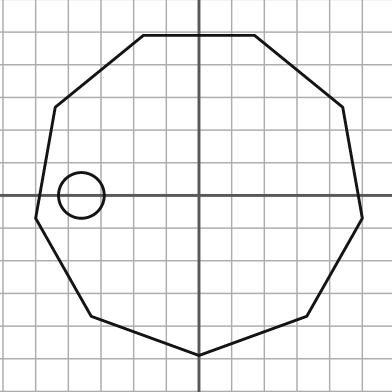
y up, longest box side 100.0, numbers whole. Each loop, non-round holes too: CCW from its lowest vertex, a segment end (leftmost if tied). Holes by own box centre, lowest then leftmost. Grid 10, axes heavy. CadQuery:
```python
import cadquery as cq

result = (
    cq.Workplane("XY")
    .moveTo(0.0, -49.0)
    .lineTo(33.0, -37.0)
    .lineTo(50.0, -7.0)
    .lineTo(44.0, 27.0)
    .lineTo(17.0, 49.0)
    .lineTo(-17.0, 49.0)
    .lineTo(-44.0, 27.0)
    .lineTo(-50.0, -7.0)
    .lineTo(-33.0, -37.0)
    .close()
    .moveTo(-36.0, 0.0)
    .circle(7.0)
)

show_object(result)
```